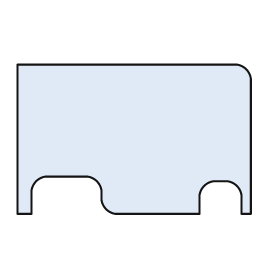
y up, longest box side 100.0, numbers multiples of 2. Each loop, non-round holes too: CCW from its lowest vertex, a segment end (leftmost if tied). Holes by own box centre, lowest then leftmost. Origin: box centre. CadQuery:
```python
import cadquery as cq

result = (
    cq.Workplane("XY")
    .moveTo(-50.0, -32.0)
    .lineTo(-44.0, -32.0)
    .lineTo(-44.0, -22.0)
    .threePointArc((-42.0, -18.0), (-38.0, -16.0))
    .lineTo(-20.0, -16.0)
    .threePointArc((-16.0, -18.0), (-14.0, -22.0))
    .lineTo(-14.0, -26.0)
    .threePointArc((-12.0, -30.0), (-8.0, -32.0))
    .lineTo(28.0, -32.0)
    .lineTo(28.0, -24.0)
    .threePointArc((30.0, -20.0), (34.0, -18.0))
    .lineTo(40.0, -18.0)
    .threePointArc((44.0, -20.0), (46.0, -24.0))
    .lineTo(46.0, -32.0)
    .lineTo(50.0, -32.0)
    .lineTo(50.0, 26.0)
    .threePointArc((48.0, 30.0), (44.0, 32.0))
    .lineTo(-50.0, 32.0)
    .close()
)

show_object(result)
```